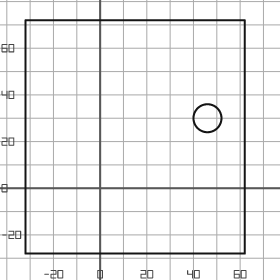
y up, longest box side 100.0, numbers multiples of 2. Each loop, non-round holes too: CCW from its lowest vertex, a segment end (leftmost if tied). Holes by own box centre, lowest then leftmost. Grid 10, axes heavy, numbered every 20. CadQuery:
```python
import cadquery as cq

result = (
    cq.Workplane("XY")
    .moveTo(-32.0, -28.0)
    .lineTo(62.0, -28.0)
    .lineTo(62.0, 72.0)
    .lineTo(-32.0, 72.0)
    .close()
    .moveTo(46.0, 30.0)
    .circle(6.0)
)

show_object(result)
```